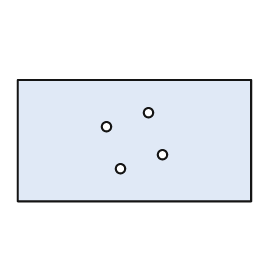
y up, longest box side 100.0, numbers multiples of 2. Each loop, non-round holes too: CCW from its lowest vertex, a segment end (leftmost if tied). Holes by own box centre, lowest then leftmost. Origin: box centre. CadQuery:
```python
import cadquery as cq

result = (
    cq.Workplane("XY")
    .moveTo(-50.0, -26.0)
    .lineTo(50.0, -26.0)
    .lineTo(50.0, 26.0)
    .lineTo(-50.0, 26.0)
    .close()
    .moveTo(-6.0, -12.0)
    .circle(2.0)
    .moveTo(12.0, -6.0)
    .circle(2.0)
    .moveTo(-12.0, 6.0)
    .circle(2.0)
    .moveTo(6.0, 12.0)
    .circle(2.0)
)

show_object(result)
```